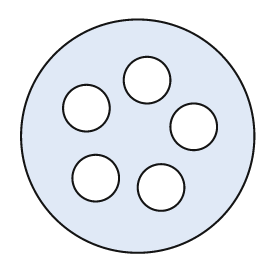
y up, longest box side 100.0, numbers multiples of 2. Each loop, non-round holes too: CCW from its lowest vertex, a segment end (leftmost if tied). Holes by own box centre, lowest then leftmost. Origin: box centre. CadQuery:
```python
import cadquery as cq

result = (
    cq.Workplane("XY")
    .moveTo(0.0, 0.0)
    .circle(50.0)
    .moveTo(10.0, -22.0)
    .circle(10.0)
    .moveTo(-18.0, -18.0)
    .circle(10.0)
    .moveTo(24.0, 4.0)
    .circle(10.0)
    .moveTo(-22.0, 12.0)
    .circle(10.0)
    .moveTo(4.0, 24.0)
    .circle(10.0)
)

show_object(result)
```